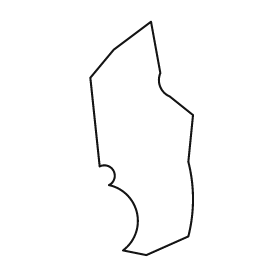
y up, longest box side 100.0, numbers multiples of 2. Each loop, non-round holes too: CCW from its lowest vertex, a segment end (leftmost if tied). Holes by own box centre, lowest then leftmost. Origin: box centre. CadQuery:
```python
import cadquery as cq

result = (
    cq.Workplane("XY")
    .moveTo(2.0, -50.0)
    .lineTo(20.0, -42.0)
    .threePointArc((22.0, -26.0), (20.0, -10.0))
    .lineTo(22.0, 10.0)
    .lineTo(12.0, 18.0)
    .threePointArc((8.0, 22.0), (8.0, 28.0))
    .lineTo(4.0, 50.0)
    .lineTo(-12.0, 38.0)
    .lineTo(-22.0, 26.0)
    .lineTo(-18.0, -12.0)
    .threePointArc((-12.0, -14.0), (-14.0, -20.0))
    .threePointArc((-2.0, -32.0), (-8.0, -48.0))
    .close()
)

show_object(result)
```